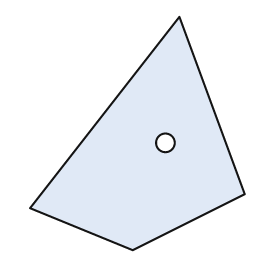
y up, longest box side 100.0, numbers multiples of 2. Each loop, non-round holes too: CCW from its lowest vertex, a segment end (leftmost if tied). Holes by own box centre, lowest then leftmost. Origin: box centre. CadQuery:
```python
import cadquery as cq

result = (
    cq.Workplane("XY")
    .moveTo(-2.0, -50.0)
    .lineTo(46.0, -26.0)
    .lineTo(18.0, 50.0)
    .lineTo(-46.0, -32.0)
    .close()
    .moveTo(12.0, -4.0)
    .circle(4.0)
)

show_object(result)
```